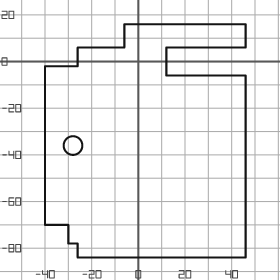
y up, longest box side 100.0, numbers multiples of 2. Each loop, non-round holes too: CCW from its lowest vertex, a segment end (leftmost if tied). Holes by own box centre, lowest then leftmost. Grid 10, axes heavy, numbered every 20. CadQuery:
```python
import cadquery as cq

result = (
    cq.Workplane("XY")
    .moveTo(-26.0, -84.0)
    .lineTo(46.0, -84.0)
    .lineTo(46.0, -6.0)
    .lineTo(12.0, -6.0)
    .lineTo(12.0, 6.0)
    .lineTo(46.0, 6.0)
    .lineTo(46.0, 16.0)
    .lineTo(-6.0, 16.0)
    .lineTo(-6.0, 6.0)
    .lineTo(-26.0, 6.0)
    .lineTo(-26.0, -2.0)
    .lineTo(-40.0, -2.0)
    .lineTo(-40.0, -70.0)
    .lineTo(-30.0, -70.0)
    .lineTo(-30.0, -78.0)
    .lineTo(-26.0, -78.0)
    .close()
    .moveTo(-28.0, -36.0)
    .circle(4.0)
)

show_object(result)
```